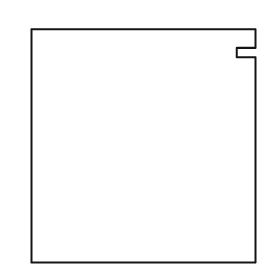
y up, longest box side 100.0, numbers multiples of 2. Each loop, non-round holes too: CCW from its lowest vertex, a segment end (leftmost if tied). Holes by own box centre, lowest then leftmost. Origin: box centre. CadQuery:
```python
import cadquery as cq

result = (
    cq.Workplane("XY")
    .moveTo(-48.0, -50.0)
    .lineTo(48.0, -50.0)
    .lineTo(48.0, 38.0)
    .lineTo(40.0, 38.0)
    .lineTo(40.0, 42.0)
    .lineTo(48.0, 42.0)
    .lineTo(48.0, 50.0)
    .lineTo(-48.0, 50.0)
    .close()
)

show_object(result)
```